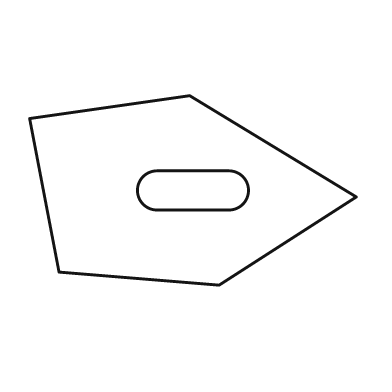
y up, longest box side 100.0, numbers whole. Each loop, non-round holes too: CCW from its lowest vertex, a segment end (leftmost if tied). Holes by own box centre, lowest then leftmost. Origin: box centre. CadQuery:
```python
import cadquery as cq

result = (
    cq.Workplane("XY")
    .moveTo(8.0, -29.0)
    .lineTo(50.0, -2.0)
    .lineTo(-1.0, 29.0)
    .lineTo(-50.0, 22.0)
    .lineTo(-41.0, -25.0)
    .close()
    .moveTo(-11.0, -6.0)
    .lineTo(11.0, -6.0)
    .threePointArc((17.0, 0.0), (11.0, 6.0))
    .lineTo(-11.0, 6.0)
    .threePointArc((-17.0, 0.0), (-11.0, -6.0))
    .close()
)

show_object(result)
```